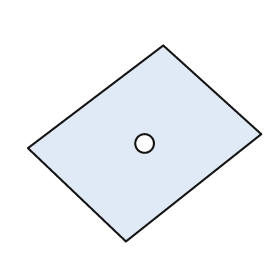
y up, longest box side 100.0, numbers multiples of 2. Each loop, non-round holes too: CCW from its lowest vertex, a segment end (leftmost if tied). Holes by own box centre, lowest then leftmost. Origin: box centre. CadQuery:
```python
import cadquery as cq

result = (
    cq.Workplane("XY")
    .moveTo(-8.0, -42.0)
    .lineTo(50.0, 4.0)
    .lineTo(8.0, 42.0)
    .lineTo(-50.0, -2.0)
    .close()
    .moveTo(0.0, 0.0)
    .circle(4.0)
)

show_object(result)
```